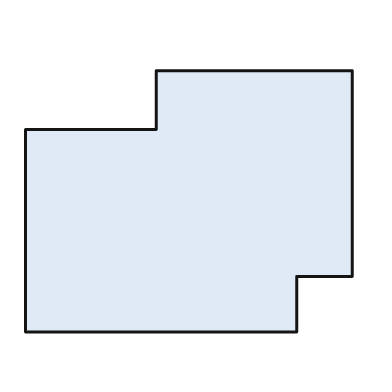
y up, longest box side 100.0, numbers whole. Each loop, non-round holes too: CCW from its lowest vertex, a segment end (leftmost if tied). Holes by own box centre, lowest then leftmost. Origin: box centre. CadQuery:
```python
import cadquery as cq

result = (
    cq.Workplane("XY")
    .moveTo(-50.0, -40.0)
    .lineTo(33.0, -40.0)
    .lineTo(33.0, -23.0)
    .lineTo(50.0, -23.0)
    .lineTo(50.0, 40.0)
    .lineTo(-10.0, 40.0)
    .lineTo(-10.0, 22.0)
    .lineTo(-50.0, 22.0)
    .close()
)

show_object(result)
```